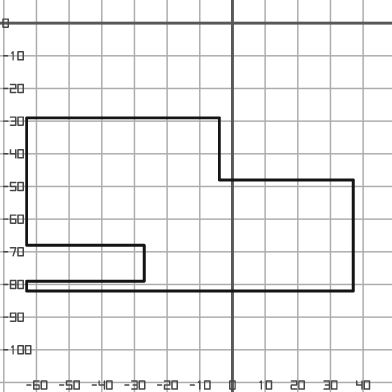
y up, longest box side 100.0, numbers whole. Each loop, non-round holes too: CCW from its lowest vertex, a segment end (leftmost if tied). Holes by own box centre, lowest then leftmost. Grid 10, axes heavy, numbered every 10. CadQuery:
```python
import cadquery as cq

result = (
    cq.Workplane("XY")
    .moveTo(-63.0, -82.0)
    .lineTo(37.0, -82.0)
    .lineTo(37.0, -48.0)
    .lineTo(-4.0, -48.0)
    .lineTo(-4.0, -29.0)
    .lineTo(-63.0, -29.0)
    .lineTo(-63.0, -68.0)
    .lineTo(-27.0, -68.0)
    .lineTo(-27.0, -79.0)
    .lineTo(-63.0, -79.0)
    .close()
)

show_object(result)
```